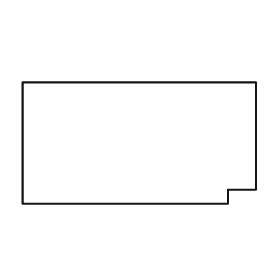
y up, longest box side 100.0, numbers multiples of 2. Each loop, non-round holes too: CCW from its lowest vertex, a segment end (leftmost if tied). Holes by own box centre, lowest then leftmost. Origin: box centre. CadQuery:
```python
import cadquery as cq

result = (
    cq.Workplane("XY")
    .moveTo(-50.0, -26.0)
    .lineTo(38.0, -26.0)
    .lineTo(38.0, -20.0)
    .lineTo(50.0, -20.0)
    .lineTo(50.0, 26.0)
    .lineTo(-50.0, 26.0)
    .close()
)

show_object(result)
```